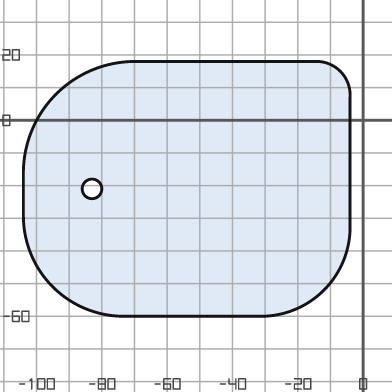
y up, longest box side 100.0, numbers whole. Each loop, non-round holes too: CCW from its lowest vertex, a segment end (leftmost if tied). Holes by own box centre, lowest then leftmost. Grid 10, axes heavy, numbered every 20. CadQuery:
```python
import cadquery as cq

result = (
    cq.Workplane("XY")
    .moveTo(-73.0, -60.0)
    .lineTo(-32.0, -60.0)
    .threePointArc((-12.0, -52.0), (-4.0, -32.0))
    .lineTo(-4.0, 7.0)
    .threePointArc((-7.0, 15.0), (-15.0, 18.0))
    .lineTo(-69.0, 18.0)
    .threePointArc((-94.0, 8.0), (-104.0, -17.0))
    .lineTo(-104.0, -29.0)
    .threePointArc((-95.0, -51.0), (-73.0, -60.0))
    .close()
    .moveTo(-83.0, -21.0)
    .circle(3.0)
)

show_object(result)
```